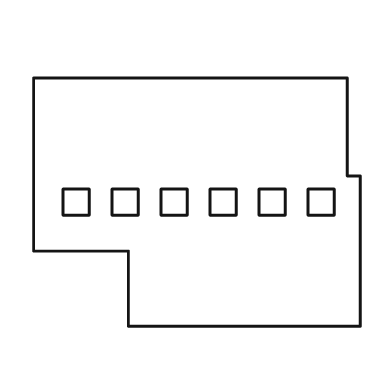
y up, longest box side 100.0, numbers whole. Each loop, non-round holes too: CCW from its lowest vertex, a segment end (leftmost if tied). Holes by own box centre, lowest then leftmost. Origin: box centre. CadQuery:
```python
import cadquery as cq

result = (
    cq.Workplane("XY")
    .moveTo(-21.0, -38.0)
    .lineTo(50.0, -38.0)
    .lineTo(50.0, 8.0)
    .lineTo(46.0, 8.0)
    .lineTo(46.0, 38.0)
    .lineTo(-50.0, 38.0)
    .lineTo(-50.0, -15.0)
    .lineTo(-21.0, -15.0)
    .close()
    .moveTo(-41.0, -4.0)
    .lineTo(-33.0, -4.0)
    .lineTo(-33.0, 4.0)
    .lineTo(-41.0, 4.0)
    .close()
    .moveTo(-26.0, -4.0)
    .lineTo(-18.0, -4.0)
    .lineTo(-18.0, 4.0)
    .lineTo(-26.0, 4.0)
    .close()
    .moveTo(-11.0, -4.0)
    .lineTo(-3.0, -4.0)
    .lineTo(-3.0, 4.0)
    .lineTo(-11.0, 4.0)
    .close()
    .moveTo(4.0, -4.0)
    .lineTo(12.0, -4.0)
    .lineTo(12.0, 4.0)
    .lineTo(4.0, 4.0)
    .close()
    .moveTo(19.0, -4.0)
    .lineTo(27.0, -4.0)
    .lineTo(27.0, 4.0)
    .lineTo(19.0, 4.0)
    .close()
    .moveTo(34.0, -4.0)
    .lineTo(42.0, -4.0)
    .lineTo(42.0, 4.0)
    .lineTo(34.0, 4.0)
    .close()
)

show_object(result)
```